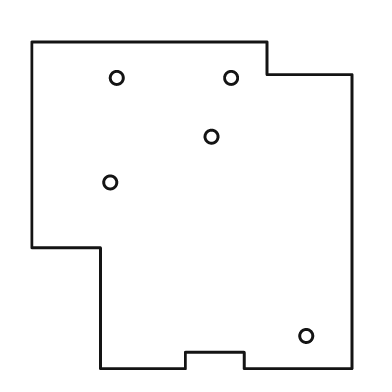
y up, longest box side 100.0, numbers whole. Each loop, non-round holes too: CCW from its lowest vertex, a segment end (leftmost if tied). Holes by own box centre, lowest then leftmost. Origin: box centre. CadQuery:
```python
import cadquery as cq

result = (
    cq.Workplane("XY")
    .moveTo(-28.0, -50.0)
    .lineTo(-2.0, -50.0)
    .lineTo(-2.0, -45.0)
    .lineTo(16.0, -45.0)
    .lineTo(16.0, -50.0)
    .lineTo(49.0, -50.0)
    .lineTo(49.0, 40.0)
    .lineTo(23.0, 40.0)
    .lineTo(23.0, 50.0)
    .lineTo(-49.0, 50.0)
    .lineTo(-49.0, -13.0)
    .lineTo(-28.0, -13.0)
    .close()
    .moveTo(35.0, -40.0)
    .circle(2.0)
    .moveTo(-25.0, 7.0)
    .circle(2.0)
    .moveTo(6.0, 21.0)
    .circle(2.0)
    .moveTo(-23.0, 39.0)
    .circle(2.0)
    .moveTo(12.0, 39.0)
    .circle(2.0)
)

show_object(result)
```